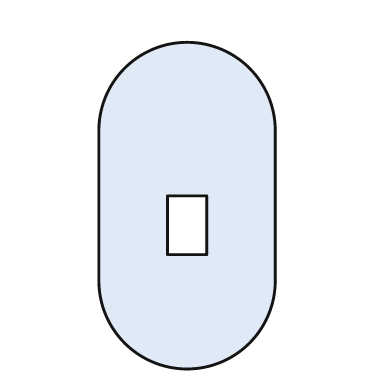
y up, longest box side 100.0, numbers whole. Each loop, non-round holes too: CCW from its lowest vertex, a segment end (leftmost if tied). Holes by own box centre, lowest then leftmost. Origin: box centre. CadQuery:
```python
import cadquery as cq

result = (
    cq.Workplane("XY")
    .moveTo(-27.0, -23.0)
    .threePointArc((0.0, -50.0), (27.0, -23.0))
    .lineTo(27.0, 23.0)
    .threePointArc((0.0, 50.0), (-27.0, 23.0))
    .close()
    .moveTo(-6.0, -15.0)
    .lineTo(6.0, -15.0)
    .lineTo(6.0, 3.0)
    .lineTo(-6.0, 3.0)
    .close()
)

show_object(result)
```